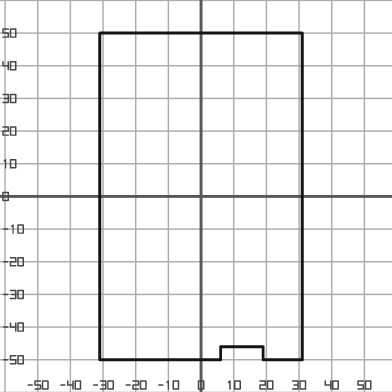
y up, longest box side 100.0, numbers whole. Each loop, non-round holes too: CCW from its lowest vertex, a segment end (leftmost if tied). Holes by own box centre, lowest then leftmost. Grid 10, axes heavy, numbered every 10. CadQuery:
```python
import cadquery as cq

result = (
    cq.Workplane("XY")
    .moveTo(-31.0, -50.0)
    .lineTo(6.0, -50.0)
    .lineTo(6.0, -46.0)
    .lineTo(19.0, -46.0)
    .lineTo(19.0, -50.0)
    .lineTo(31.0, -50.0)
    .lineTo(31.0, 50.0)
    .lineTo(-31.0, 50.0)
    .close()
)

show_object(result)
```